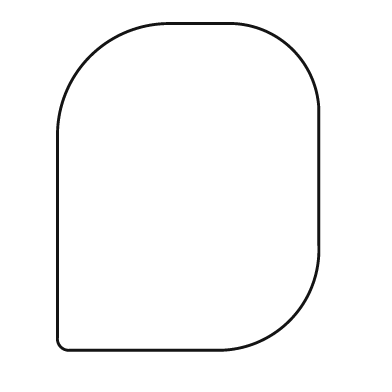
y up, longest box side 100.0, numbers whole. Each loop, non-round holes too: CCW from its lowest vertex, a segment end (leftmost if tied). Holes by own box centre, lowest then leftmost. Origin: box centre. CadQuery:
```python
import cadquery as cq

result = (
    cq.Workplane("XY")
    .moveTo(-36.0, -50.0)
    .lineTo(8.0, -50.0)
    .threePointArc((31.0, -41.0), (40.0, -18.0))
    .lineTo(40.0, 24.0)
    .threePointArc((32.0, 42.0), (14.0, 50.0))
    .lineTo(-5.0, 50.0)
    .threePointArc((-30.0, 40.0), (-40.0, 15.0))
    .lineTo(-40.0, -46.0)
    .threePointArc((-39.0, -49.0), (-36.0, -50.0))
    .close()
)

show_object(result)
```